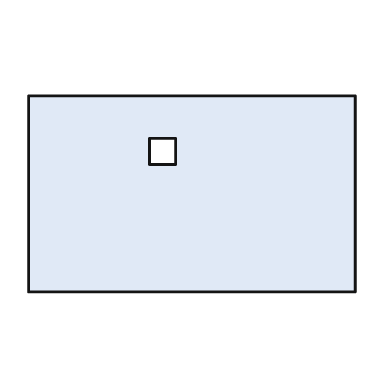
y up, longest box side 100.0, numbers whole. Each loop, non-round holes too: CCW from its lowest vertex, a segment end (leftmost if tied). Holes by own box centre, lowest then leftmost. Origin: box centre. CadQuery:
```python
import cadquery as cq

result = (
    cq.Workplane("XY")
    .moveTo(-50.0, -30.0)
    .lineTo(50.0, -30.0)
    .lineTo(50.0, 30.0)
    .lineTo(-50.0, 30.0)
    .close()
    .moveTo(-13.0, 9.0)
    .lineTo(-5.0, 9.0)
    .lineTo(-5.0, 17.0)
    .lineTo(-13.0, 17.0)
    .close()
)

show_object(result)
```